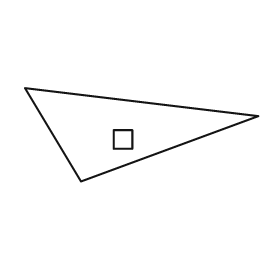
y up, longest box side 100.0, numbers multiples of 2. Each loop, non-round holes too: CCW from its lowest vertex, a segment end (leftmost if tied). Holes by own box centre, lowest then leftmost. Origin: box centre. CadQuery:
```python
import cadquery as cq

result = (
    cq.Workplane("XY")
    .moveTo(-26.0, -20.0)
    .lineTo(50.0, 8.0)
    .lineTo(-50.0, 20.0)
    .close()
    .moveTo(-12.0, -6.0)
    .lineTo(-4.0, -6.0)
    .lineTo(-4.0, 2.0)
    .lineTo(-12.0, 2.0)
    .close()
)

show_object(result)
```